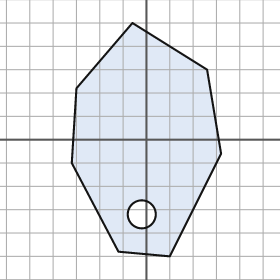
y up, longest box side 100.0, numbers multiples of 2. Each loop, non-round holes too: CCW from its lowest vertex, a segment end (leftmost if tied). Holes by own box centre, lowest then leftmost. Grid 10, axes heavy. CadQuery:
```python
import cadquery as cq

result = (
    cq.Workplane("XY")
    .moveTo(10.0, -50.0)
    .lineTo(32.0, -6.0)
    .lineTo(26.0, 30.0)
    .lineTo(-6.0, 50.0)
    .lineTo(-30.0, 22.0)
    .lineTo(-32.0, -10.0)
    .lineTo(-12.0, -48.0)
    .close()
    .moveTo(-2.0, -32.0)
    .circle(6.0)
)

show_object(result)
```